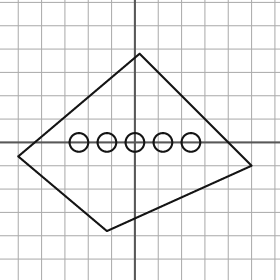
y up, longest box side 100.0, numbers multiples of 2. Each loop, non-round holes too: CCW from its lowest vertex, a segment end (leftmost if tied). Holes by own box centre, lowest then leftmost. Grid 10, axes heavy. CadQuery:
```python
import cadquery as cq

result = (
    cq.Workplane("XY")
    .moveTo(-12.0, -38.0)
    .lineTo(50.0, -10.0)
    .lineTo(2.0, 38.0)
    .lineTo(-50.0, -6.0)
    .close()
    .moveTo(-24.0, 0.0)
    .circle(4.0)
    .moveTo(-12.0, 0.0)
    .circle(4.0)
    .moveTo(0.0, 0.0)
    .circle(4.0)
    .moveTo(12.0, 0.0)
    .circle(4.0)
    .moveTo(24.0, 0.0)
    .circle(4.0)
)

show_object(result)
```